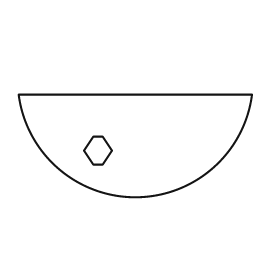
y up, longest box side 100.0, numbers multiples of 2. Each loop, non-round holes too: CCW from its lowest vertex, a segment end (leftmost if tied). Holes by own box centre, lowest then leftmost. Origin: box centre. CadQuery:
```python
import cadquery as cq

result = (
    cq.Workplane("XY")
    .moveTo(-50.0, 22.0)
    .threePointArc((0.0, -22.0), (50.0, 22.0))
    .close()
    .moveTo(-18.0, -8.0)
    .lineTo(-14.0, -8.0)
    .lineTo(-10.0, -2.0)
    .lineTo(-14.0, 4.0)
    .lineTo(-18.0, 4.0)
    .lineTo(-22.0, -2.0)
    .close()
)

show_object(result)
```